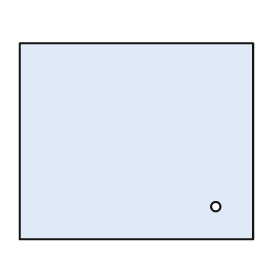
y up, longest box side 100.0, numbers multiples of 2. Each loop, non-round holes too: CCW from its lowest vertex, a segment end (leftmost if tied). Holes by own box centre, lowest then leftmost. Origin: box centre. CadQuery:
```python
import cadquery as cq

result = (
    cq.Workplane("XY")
    .moveTo(-50.0, -42.0)
    .lineTo(50.0, -42.0)
    .lineTo(50.0, 42.0)
    .lineTo(-50.0, 42.0)
    .close()
    .moveTo(34.0, -28.0)
    .circle(2.0)
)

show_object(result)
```